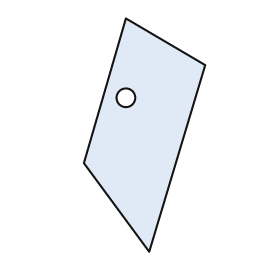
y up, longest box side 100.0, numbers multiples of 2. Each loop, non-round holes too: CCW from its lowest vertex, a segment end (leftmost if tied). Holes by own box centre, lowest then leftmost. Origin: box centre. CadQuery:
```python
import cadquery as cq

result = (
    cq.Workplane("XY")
    .moveTo(2.0, -50.0)
    .lineTo(26.0, 30.0)
    .lineTo(-8.0, 50.0)
    .lineTo(-26.0, -12.0)
    .close()
    .moveTo(-8.0, 16.0)
    .circle(4.0)
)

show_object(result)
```